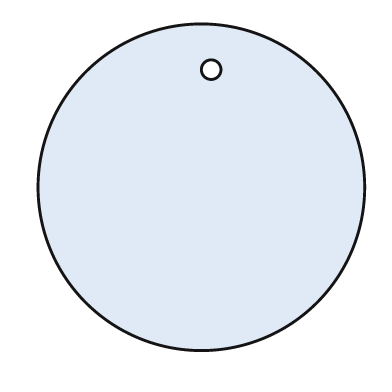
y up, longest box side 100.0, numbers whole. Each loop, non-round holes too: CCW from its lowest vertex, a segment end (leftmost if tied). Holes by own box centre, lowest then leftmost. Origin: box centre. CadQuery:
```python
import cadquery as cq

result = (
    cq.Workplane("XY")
    .moveTo(0.0, 0.0)
    .circle(50.0)
    .moveTo(3.0, 36.0)
    .circle(3.0)
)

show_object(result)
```